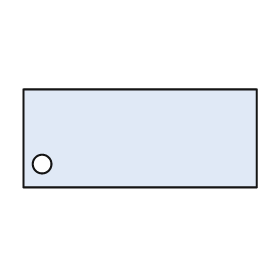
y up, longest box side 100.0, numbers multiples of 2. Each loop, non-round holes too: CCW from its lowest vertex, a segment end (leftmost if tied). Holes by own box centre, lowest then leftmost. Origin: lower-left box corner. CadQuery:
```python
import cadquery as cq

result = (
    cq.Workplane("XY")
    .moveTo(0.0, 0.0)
    .lineTo(100.0, 0.0)
    .lineTo(100.0, 42.0)
    .lineTo(0.0, 42.0)
    .close()
    .moveTo(8.0, 10.0)
    .circle(4.0)
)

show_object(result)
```